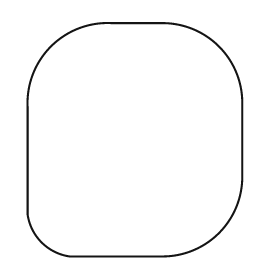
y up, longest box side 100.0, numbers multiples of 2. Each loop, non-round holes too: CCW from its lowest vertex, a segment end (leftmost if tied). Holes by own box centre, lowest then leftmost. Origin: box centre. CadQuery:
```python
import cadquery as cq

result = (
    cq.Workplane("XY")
    .moveTo(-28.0, -50.0)
    .lineTo(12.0, -50.0)
    .threePointArc((36.0, -40.0), (46.0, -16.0))
    .lineTo(46.0, 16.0)
    .threePointArc((36.0, 40.0), (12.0, 50.0))
    .lineTo(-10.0, 50.0)
    .threePointArc((-36.0, 40.0), (-46.0, 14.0))
    .lineTo(-46.0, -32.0)
    .threePointArc((-40.0, -44.0), (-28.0, -50.0))
    .close()
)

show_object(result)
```